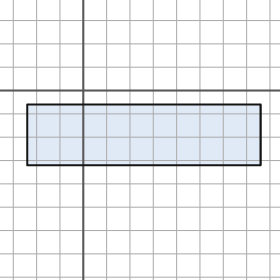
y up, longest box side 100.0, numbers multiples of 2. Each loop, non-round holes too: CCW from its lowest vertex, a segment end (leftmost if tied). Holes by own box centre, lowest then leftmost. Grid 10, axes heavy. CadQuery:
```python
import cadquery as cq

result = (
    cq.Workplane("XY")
    .moveTo(-24.0, -32.0)
    .lineTo(76.0, -32.0)
    .lineTo(76.0, -6.0)
    .lineTo(-24.0, -6.0)
    .close()
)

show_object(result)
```